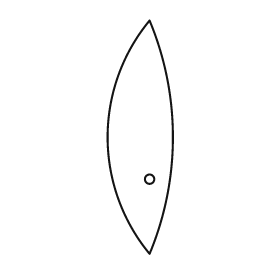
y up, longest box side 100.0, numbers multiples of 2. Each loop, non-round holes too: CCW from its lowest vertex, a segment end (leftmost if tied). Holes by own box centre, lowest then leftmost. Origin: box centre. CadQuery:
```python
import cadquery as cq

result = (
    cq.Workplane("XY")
    .moveTo(4.0, -50.0)
    .threePointArc((14.0, 0.0), (4.0, 50.0))
    .threePointArc((-14.0, 0.0), (4.0, -50.0))
    .close()
    .moveTo(4.0, -18.0)
    .circle(2.0)
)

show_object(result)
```